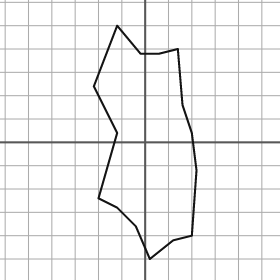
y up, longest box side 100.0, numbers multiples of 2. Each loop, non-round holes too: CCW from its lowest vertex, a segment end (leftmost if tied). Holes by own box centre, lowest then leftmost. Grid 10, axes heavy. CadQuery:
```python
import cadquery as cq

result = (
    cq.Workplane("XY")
    .moveTo(2.0, -50.0)
    .lineTo(12.0, -42.0)
    .lineTo(20.0, -40.0)
    .lineTo(22.0, -12.0)
    .lineTo(20.0, 4.0)
    .lineTo(16.0, 16.0)
    .lineTo(14.0, 40.0)
    .lineTo(6.0, 38.0)
    .lineTo(-2.0, 38.0)
    .lineTo(-12.0, 50.0)
    .lineTo(-22.0, 24.0)
    .lineTo(-12.0, 4.0)
    .lineTo(-20.0, -24.0)
    .lineTo(-12.0, -28.0)
    .lineTo(-4.0, -36.0)
    .close()
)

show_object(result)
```